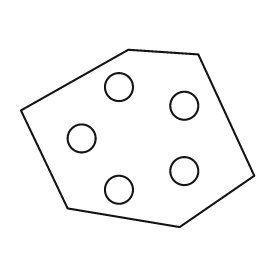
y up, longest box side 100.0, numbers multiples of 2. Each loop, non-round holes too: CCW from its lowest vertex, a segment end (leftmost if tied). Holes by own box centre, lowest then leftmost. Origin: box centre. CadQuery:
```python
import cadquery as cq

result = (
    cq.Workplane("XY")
    .moveTo(18.0, -38.0)
    .lineTo(50.0, -16.0)
    .lineTo(26.0, 36.0)
    .lineTo(-4.0, 38.0)
    .lineTo(-50.0, 12.0)
    .lineTo(-30.0, -30.0)
    .close()
    .moveTo(-8.0, -22.0)
    .circle(6.0)
    .moveTo(20.0, -14.0)
    .circle(6.0)
    .moveTo(-24.0, 0.0)
    .circle(6.0)
    .moveTo(20.0, 14.0)
    .circle(6.0)
    .moveTo(-8.0, 22.0)
    .circle(6.0)
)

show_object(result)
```